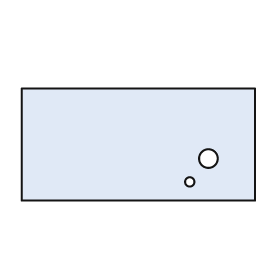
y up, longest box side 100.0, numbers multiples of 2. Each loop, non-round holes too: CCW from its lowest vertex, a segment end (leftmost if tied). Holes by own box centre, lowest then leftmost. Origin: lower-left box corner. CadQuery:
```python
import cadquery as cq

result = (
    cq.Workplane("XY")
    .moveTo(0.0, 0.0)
    .lineTo(100.0, 0.0)
    .lineTo(100.0, 48.0)
    .lineTo(0.0, 48.0)
    .close()
    .moveTo(72.0, 8.0)
    .circle(2.0)
    .moveTo(80.0, 18.0)
    .circle(4.0)
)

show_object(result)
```